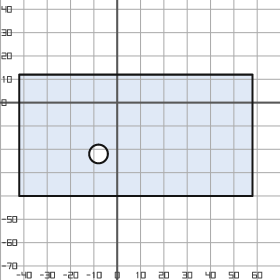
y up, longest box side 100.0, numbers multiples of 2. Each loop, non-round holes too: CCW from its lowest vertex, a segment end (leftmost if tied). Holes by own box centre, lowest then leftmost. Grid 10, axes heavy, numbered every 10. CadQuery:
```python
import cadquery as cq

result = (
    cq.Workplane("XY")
    .moveTo(-42.0, -40.0)
    .lineTo(58.0, -40.0)
    .lineTo(58.0, 12.0)
    .lineTo(-42.0, 12.0)
    .close()
    .moveTo(-8.0, -22.0)
    .circle(4.0)
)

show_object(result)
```